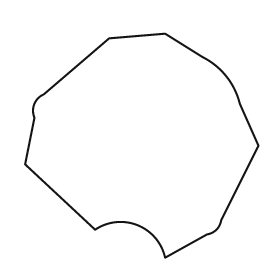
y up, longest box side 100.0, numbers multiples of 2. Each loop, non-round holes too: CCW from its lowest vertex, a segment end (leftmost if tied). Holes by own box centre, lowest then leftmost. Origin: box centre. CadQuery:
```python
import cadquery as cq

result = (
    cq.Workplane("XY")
    .moveTo(10.0, -48.0)
    .lineTo(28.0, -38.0)
    .threePointArc((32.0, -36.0), (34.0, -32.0))
    .lineTo(50.0, 0.0)
    .lineTo(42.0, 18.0)
    .threePointArc((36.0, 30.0), (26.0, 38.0))
    .lineTo(10.0, 48.0)
    .lineTo(-14.0, 46.0)
    .lineTo(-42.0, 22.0)
    .threePointArc((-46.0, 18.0), (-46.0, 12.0))
    .lineTo(-50.0, -8.0)
    .lineTo(-20.0, -36.0)
    .threePointArc((-2.0, -34.0), (10.0, -48.0))
    .close()
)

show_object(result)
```